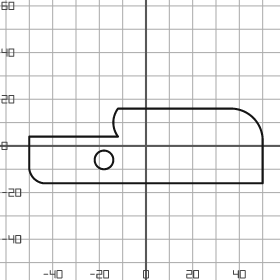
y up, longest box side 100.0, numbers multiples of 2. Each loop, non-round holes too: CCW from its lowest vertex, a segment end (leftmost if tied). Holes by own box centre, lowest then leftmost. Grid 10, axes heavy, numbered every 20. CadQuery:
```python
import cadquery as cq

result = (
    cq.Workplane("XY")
    .moveTo(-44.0, -16.0)
    .lineTo(50.0, -16.0)
    .lineTo(50.0, 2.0)
    .threePointArc((46.0, 12.0), (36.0, 16.0))
    .lineTo(-12.0, 16.0)
    .threePointArc((-14.0, 10.0), (-12.0, 4.0))
    .lineTo(-50.0, 4.0)
    .lineTo(-50.0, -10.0)
    .threePointArc((-48.0, -14.0), (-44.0, -16.0))
    .close()
    .moveTo(-18.0, -6.0)
    .circle(4.0)
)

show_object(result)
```